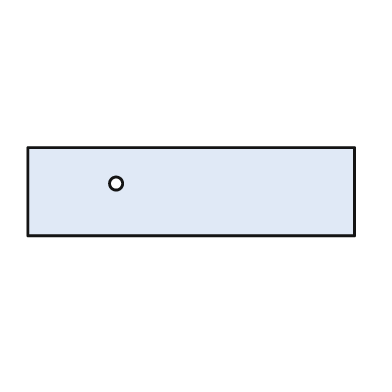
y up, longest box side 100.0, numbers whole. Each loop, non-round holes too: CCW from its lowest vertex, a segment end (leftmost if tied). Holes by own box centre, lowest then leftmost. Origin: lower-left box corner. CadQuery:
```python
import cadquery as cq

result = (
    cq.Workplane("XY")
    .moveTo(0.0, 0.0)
    .lineTo(100.0, 0.0)
    .lineTo(100.0, 27.0)
    .lineTo(0.0, 27.0)
    .close()
    .moveTo(27.0, 16.0)
    .circle(2.0)
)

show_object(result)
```